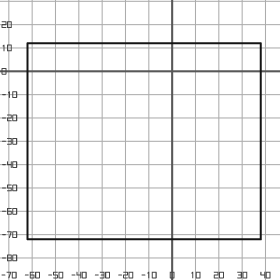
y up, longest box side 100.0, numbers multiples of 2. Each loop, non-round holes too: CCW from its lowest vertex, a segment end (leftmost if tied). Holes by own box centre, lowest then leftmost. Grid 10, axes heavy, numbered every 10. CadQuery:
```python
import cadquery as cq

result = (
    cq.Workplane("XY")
    .moveTo(-62.0, -72.0)
    .lineTo(38.0, -72.0)
    .lineTo(38.0, 12.0)
    .lineTo(-62.0, 12.0)
    .close()
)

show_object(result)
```